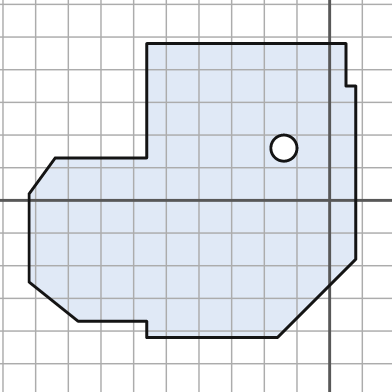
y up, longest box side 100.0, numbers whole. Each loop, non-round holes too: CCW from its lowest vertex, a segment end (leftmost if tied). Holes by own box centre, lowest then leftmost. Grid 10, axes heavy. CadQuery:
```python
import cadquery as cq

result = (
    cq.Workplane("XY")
    .moveTo(-56.0, -42.0)
    .lineTo(-16.0, -42.0)
    .lineTo(8.0, -18.0)
    .lineTo(8.0, 35.0)
    .lineTo(5.0, 35.0)
    .lineTo(5.0, 48.0)
    .lineTo(-56.0, 48.0)
    .lineTo(-56.0, 13.0)
    .lineTo(-84.0, 13.0)
    .lineTo(-92.0, 2.0)
    .lineTo(-92.0, -25.0)
    .lineTo(-77.0, -37.0)
    .lineTo(-56.0, -37.0)
    .close()
    .moveTo(-14.0, 16.0)
    .circle(4.0)
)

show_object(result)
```